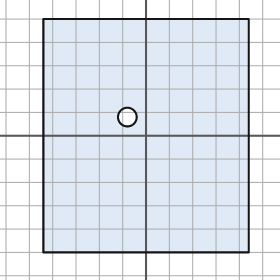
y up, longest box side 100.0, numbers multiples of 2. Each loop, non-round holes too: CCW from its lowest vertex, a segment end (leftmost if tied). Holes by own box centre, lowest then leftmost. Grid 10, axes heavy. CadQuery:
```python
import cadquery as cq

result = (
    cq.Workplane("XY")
    .moveTo(-44.0, -50.0)
    .lineTo(44.0, -50.0)
    .lineTo(44.0, 50.0)
    .lineTo(-44.0, 50.0)
    .close()
    .moveTo(-8.0, 8.0)
    .circle(4.0)
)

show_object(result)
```